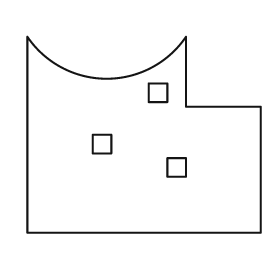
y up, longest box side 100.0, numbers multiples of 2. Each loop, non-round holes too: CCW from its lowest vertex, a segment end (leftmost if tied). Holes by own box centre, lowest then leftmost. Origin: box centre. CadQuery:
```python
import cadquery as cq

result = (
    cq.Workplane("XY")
    .moveTo(-50.0, -42.0)
    .lineTo(50.0, -42.0)
    .lineTo(50.0, 12.0)
    .lineTo(18.0, 12.0)
    .lineTo(18.0, 42.0)
    .threePointArc((-16.0, 24.0), (-50.0, 42.0))
    .close()
    .moveTo(10.0, -18.0)
    .lineTo(18.0, -18.0)
    .lineTo(18.0, -10.0)
    .lineTo(10.0, -10.0)
    .close()
    .moveTo(-22.0, -8.0)
    .lineTo(-14.0, -8.0)
    .lineTo(-14.0, 0.0)
    .lineTo(-22.0, 0.0)
    .close()
    .moveTo(2.0, 14.0)
    .lineTo(10.0, 14.0)
    .lineTo(10.0, 22.0)
    .lineTo(2.0, 22.0)
    .close()
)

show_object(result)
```